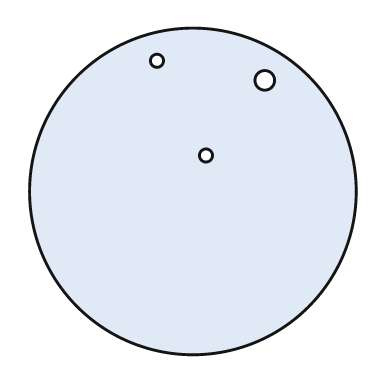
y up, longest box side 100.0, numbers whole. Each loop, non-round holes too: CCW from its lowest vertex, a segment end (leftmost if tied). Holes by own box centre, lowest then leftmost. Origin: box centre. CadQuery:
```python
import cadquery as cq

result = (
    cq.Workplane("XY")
    .moveTo(0.0, 0.0)
    .circle(50.0)
    .moveTo(4.0, 11.0)
    .circle(2.0)
    .moveTo(22.0, 34.0)
    .circle(3.0)
    .moveTo(-11.0, 40.0)
    .circle(2.0)
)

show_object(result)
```